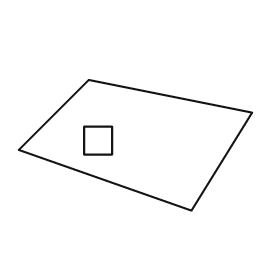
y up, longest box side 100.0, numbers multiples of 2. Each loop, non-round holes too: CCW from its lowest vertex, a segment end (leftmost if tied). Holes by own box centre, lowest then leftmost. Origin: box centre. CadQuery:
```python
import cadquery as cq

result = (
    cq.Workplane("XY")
    .moveTo(24.0, -28.0)
    .lineTo(50.0, 14.0)
    .lineTo(-20.0, 28.0)
    .lineTo(-50.0, -2.0)
    .close()
    .moveTo(-22.0, -4.0)
    .lineTo(-10.0, -4.0)
    .lineTo(-10.0, 8.0)
    .lineTo(-22.0, 8.0)
    .close()
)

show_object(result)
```